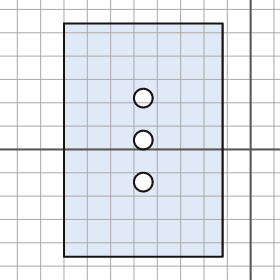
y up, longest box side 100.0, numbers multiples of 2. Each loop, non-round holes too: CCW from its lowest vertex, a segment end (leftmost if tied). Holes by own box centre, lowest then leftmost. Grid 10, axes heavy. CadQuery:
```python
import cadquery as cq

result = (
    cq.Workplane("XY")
    .moveTo(-80.0, -46.0)
    .lineTo(-12.0, -46.0)
    .lineTo(-12.0, 54.0)
    .lineTo(-80.0, 54.0)
    .close()
    .moveTo(-46.0, -14.0)
    .circle(4.0)
    .moveTo(-46.0, 4.0)
    .circle(4.0)
    .moveTo(-46.0, 22.0)
    .circle(4.0)
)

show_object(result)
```